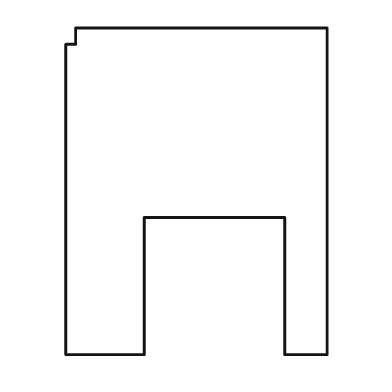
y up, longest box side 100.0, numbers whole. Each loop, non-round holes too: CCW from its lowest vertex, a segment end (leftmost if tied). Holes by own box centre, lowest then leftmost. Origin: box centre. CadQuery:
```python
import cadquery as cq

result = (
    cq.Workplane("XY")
    .moveTo(-40.0, -50.0)
    .lineTo(-16.0, -50.0)
    .lineTo(-16.0, -8.0)
    .lineTo(27.0, -8.0)
    .lineTo(27.0, -50.0)
    .lineTo(40.0, -50.0)
    .lineTo(40.0, 50.0)
    .lineTo(-37.0, 50.0)
    .lineTo(-37.0, 45.0)
    .lineTo(-40.0, 45.0)
    .close()
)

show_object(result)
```